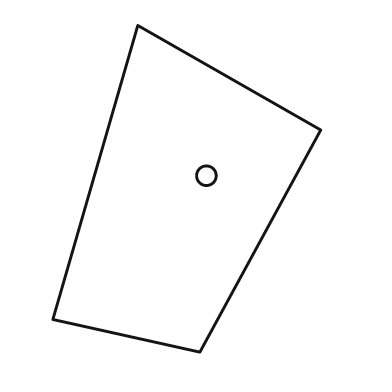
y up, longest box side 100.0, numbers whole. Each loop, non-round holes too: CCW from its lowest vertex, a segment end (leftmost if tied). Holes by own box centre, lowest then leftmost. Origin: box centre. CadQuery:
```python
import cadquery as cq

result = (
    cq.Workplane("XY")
    .moveTo(4.0, -50.0)
    .lineTo(41.0, 18.0)
    .lineTo(-15.0, 50.0)
    .lineTo(-41.0, -40.0)
    .close()
    .moveTo(6.0, 4.0)
    .circle(3.0)
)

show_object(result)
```